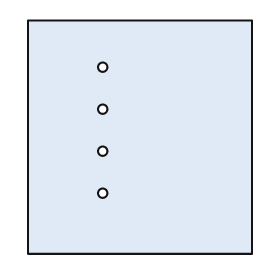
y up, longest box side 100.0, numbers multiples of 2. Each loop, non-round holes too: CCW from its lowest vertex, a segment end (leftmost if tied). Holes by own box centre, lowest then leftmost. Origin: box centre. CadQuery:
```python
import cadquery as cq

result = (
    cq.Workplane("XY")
    .moveTo(-48.0, -50.0)
    .lineTo(48.0, -50.0)
    .lineTo(48.0, 50.0)
    .lineTo(-48.0, 50.0)
    .close()
    .moveTo(-16.0, -24.0)
    .circle(2.0)
    .moveTo(-16.0, -6.0)
    .circle(2.0)
    .moveTo(-16.0, 12.0)
    .circle(2.0)
    .moveTo(-16.0, 30.0)
    .circle(2.0)
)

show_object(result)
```